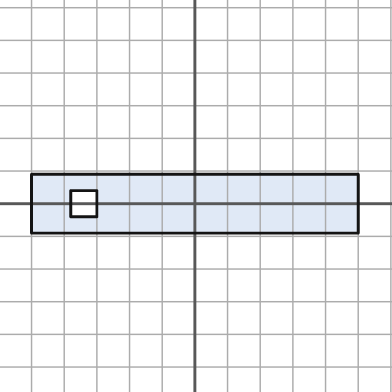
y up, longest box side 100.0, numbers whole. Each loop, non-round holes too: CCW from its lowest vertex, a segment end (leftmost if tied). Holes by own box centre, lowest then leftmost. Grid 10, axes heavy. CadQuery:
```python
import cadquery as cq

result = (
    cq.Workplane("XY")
    .moveTo(-50.0, -9.0)
    .lineTo(50.0, -9.0)
    .lineTo(50.0, 9.0)
    .lineTo(-50.0, 9.0)
    .close()
    .moveTo(-38.0, -4.0)
    .lineTo(-30.0, -4.0)
    .lineTo(-30.0, 4.0)
    .lineTo(-38.0, 4.0)
    .close()
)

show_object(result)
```